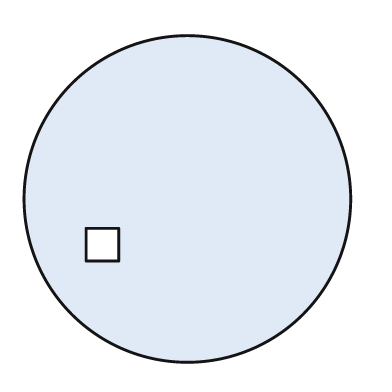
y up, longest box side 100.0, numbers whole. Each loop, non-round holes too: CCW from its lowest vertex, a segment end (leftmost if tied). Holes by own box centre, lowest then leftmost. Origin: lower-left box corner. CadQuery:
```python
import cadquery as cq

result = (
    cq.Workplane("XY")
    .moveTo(50.0, 50.0)
    .circle(50.0)
    .moveTo(19.0, 31.0)
    .lineTo(29.0, 31.0)
    .lineTo(29.0, 41.0)
    .lineTo(19.0, 41.0)
    .close()
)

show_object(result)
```